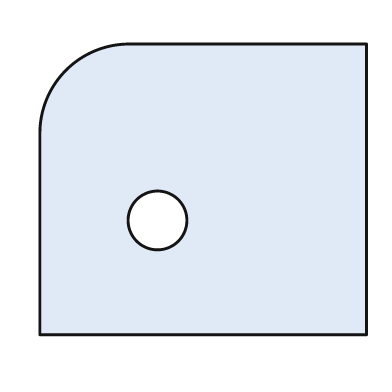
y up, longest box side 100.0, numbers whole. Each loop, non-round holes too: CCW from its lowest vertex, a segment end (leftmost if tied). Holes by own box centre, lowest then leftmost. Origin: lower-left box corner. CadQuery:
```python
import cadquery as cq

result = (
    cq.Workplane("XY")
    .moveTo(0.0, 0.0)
    .lineTo(100.0, 0.0)
    .lineTo(100.0, 89.0)
    .lineTo(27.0, 89.0)
    .threePointArc((8.0, 81.0), (0.0, 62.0))
    .close()
    .moveTo(36.0, 35.0)
    .circle(9.0)
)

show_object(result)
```